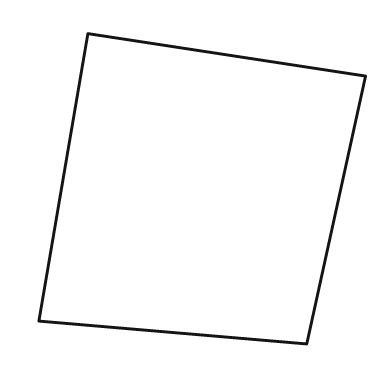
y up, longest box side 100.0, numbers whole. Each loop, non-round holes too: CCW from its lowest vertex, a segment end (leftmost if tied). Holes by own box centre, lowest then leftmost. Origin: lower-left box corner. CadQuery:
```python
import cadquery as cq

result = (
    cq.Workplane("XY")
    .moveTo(82.0, 0.0)
    .lineTo(100.0, 82.0)
    .lineTo(15.0, 95.0)
    .lineTo(0.0, 7.0)
    .close()
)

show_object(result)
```